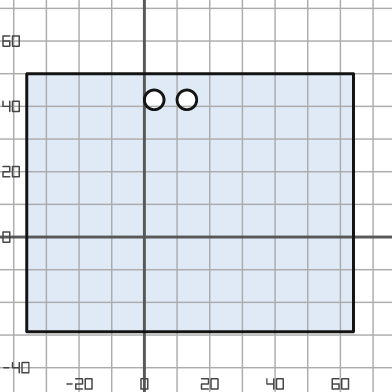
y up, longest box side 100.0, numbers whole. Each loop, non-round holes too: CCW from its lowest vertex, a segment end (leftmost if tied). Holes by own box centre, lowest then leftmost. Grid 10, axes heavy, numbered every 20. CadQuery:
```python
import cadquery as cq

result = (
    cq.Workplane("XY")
    .moveTo(-36.0, -29.0)
    .lineTo(64.0, -29.0)
    .lineTo(64.0, 50.0)
    .lineTo(-36.0, 50.0)
    .close()
    .moveTo(3.0, 42.0)
    .circle(3.0)
    .moveTo(13.0, 42.0)
    .circle(3.0)
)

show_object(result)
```